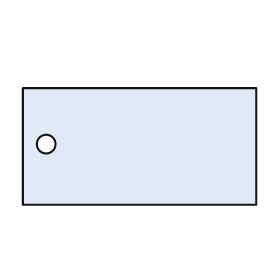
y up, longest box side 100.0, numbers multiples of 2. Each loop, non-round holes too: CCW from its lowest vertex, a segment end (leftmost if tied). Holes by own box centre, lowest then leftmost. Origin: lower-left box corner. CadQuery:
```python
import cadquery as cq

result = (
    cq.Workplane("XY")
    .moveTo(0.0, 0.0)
    .lineTo(100.0, 0.0)
    .lineTo(100.0, 50.0)
    .lineTo(0.0, 50.0)
    .close()
    .moveTo(10.0, 26.0)
    .circle(4.0)
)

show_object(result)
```